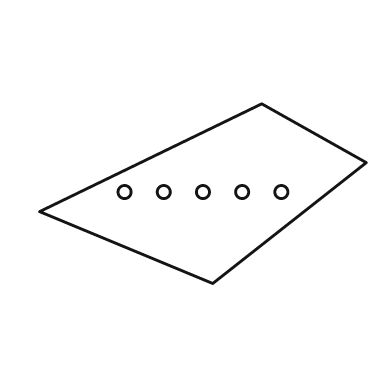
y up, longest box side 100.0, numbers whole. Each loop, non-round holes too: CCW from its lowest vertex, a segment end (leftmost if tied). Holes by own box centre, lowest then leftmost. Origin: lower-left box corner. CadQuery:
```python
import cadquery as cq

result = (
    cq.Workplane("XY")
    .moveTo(53.0, 0.0)
    .lineTo(100.0, 37.0)
    .lineTo(68.0, 55.0)
    .lineTo(0.0, 22.0)
    .close()
    .moveTo(26.0, 28.0)
    .circle(2.0)
    .moveTo(38.0, 28.0)
    .circle(2.0)
    .moveTo(50.0, 28.0)
    .circle(2.0)
    .moveTo(62.0, 28.0)
    .circle(2.0)
    .moveTo(74.0, 28.0)
    .circle(2.0)
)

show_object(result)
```